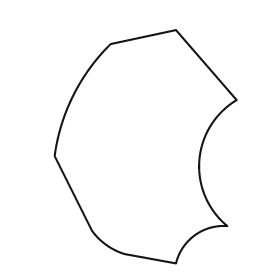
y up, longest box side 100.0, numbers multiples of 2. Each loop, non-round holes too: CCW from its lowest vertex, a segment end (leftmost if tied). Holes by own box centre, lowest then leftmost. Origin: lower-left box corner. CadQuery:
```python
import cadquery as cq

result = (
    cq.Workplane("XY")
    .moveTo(52.0, 0.0)
    .threePointArc((60.0, 12.0), (74.0, 16.0))
    .threePointArc((62.0, 44.0), (78.0, 70.0))
    .lineTo(52.0, 100.0)
    .lineTo(24.0, 94.0)
    .threePointArc((8.0, 72.0), (0.0, 46.0))
    .lineTo(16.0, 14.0)
    .threePointArc((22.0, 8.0), (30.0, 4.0))
    .close()
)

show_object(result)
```